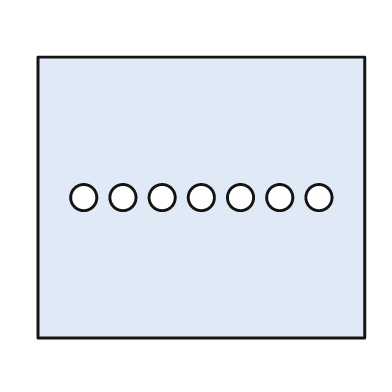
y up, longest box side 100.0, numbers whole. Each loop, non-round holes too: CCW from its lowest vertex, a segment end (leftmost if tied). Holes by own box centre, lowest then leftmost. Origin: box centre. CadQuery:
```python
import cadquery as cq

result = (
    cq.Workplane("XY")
    .moveTo(-50.0, -43.0)
    .lineTo(50.0, -43.0)
    .lineTo(50.0, 43.0)
    .lineTo(-50.0, 43.0)
    .close()
    .moveTo(-36.0, 0.0)
    .circle(4.0)
    .moveTo(-24.0, 0.0)
    .circle(4.0)
    .moveTo(-12.0, 0.0)
    .circle(4.0)
    .moveTo(0.0, 0.0)
    .circle(4.0)
    .moveTo(12.0, 0.0)
    .circle(4.0)
    .moveTo(24.0, 0.0)
    .circle(4.0)
    .moveTo(36.0, 0.0)
    .circle(4.0)
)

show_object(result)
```